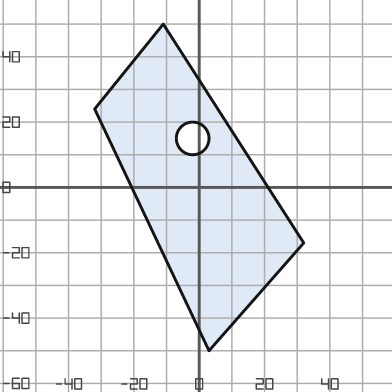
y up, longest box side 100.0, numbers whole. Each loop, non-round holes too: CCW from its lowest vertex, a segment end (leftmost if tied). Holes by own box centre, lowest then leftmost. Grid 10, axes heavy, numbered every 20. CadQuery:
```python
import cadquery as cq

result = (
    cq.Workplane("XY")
    .moveTo(3.0, -50.0)
    .lineTo(32.0, -17.0)
    .lineTo(-11.0, 50.0)
    .lineTo(-32.0, 24.0)
    .close()
    .moveTo(-2.0, 15.0)
    .circle(5.0)
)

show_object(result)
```